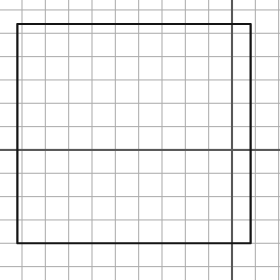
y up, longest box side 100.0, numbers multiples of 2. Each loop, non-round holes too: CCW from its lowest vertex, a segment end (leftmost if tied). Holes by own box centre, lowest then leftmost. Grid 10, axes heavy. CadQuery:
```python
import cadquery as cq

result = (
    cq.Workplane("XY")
    .moveTo(-92.0, -40.0)
    .lineTo(8.0, -40.0)
    .lineTo(8.0, 54.0)
    .lineTo(-92.0, 54.0)
    .close()
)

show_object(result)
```